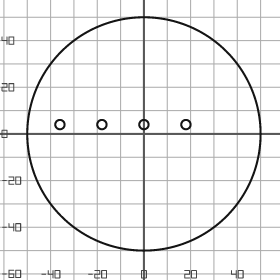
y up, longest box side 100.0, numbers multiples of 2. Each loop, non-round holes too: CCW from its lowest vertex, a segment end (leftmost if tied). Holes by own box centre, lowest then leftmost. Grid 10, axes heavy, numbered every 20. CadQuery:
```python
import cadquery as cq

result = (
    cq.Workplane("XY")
    .moveTo(0.0, 0.0)
    .circle(50.0)
    .moveTo(-36.0, 4.0)
    .circle(2.0)
    .moveTo(-18.0, 4.0)
    .circle(2.0)
    .moveTo(0.0, 4.0)
    .circle(2.0)
    .moveTo(18.0, 4.0)
    .circle(2.0)
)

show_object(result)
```